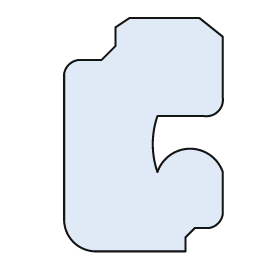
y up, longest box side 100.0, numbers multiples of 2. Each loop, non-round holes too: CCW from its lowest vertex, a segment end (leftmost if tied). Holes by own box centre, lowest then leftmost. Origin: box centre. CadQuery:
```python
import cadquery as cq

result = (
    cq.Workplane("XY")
    .moveTo(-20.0, -50.0)
    .lineTo(18.0, -50.0)
    .lineTo(18.0, -44.0)
    .lineTo(22.0, -40.0)
    .lineTo(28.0, -40.0)
    .threePointArc((32.0, -38.0), (34.0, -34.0))
    .lineTo(34.0, -16.0)
    .threePointArc((20.0, -6.0), (6.0, -16.0))
    .threePointArc((4.0, -4.0), (6.0, 8.0))
    .lineTo(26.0, 8.0)
    .threePointArc((32.0, 10.0), (34.0, 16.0))
    .lineTo(34.0, 42.0)
    .lineTo(24.0, 50.0)
    .lineTo(-6.0, 50.0)
    .lineTo(-12.0, 46.0)
    .lineTo(-12.0, 38.0)
    .lineTo(-18.0, 32.0)
    .lineTo(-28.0, 32.0)
    .threePointArc((-32.0, 30.0), (-34.0, 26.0))
    .lineTo(-34.0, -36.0)
    .threePointArc((-30.0, -46.0), (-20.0, -50.0))
    .close()
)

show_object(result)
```